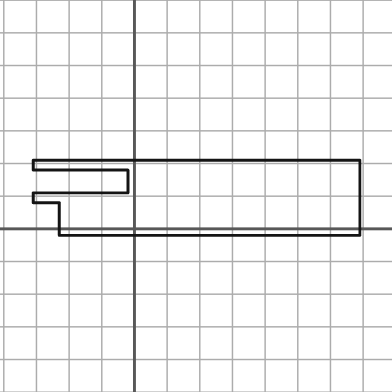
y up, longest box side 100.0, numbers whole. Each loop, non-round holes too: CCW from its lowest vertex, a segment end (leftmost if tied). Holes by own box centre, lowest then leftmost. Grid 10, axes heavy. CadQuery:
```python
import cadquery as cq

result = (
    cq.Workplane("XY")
    .moveTo(-23.0, -2.0)
    .lineTo(69.0, -2.0)
    .lineTo(69.0, 21.0)
    .lineTo(-31.0, 21.0)
    .lineTo(-31.0, 18.0)
    .lineTo(-2.0, 18.0)
    .lineTo(-2.0, 11.0)
    .lineTo(-31.0, 11.0)
    .lineTo(-31.0, 8.0)
    .lineTo(-23.0, 8.0)
    .close()
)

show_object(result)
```